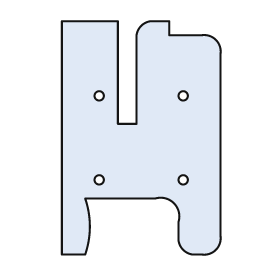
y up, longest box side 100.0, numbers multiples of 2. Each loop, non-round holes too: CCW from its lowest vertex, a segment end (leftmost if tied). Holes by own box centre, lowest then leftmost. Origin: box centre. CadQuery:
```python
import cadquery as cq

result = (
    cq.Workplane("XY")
    .moveTo(-34.0, -50.0)
    .lineTo(-24.0, -50.0)
    .threePointArc((-22.0, -38.0), (-24.0, -26.0))
    .lineTo(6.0, -26.0)
    .threePointArc((14.0, -28.0), (16.0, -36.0))
    .lineTo(16.0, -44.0)
    .threePointArc((18.0, -48.0), (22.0, -50.0))
    .lineTo(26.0, -50.0)
    .threePointArc((32.0, -48.0), (34.0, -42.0))
    .lineTo(34.0, 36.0)
    .threePointArc((32.0, 42.0), (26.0, 44.0))
    .lineTo(12.0, 44.0)
    .lineTo(12.0, 50.0)
    .lineTo(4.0, 50.0)
    .threePointArc((0.0, 48.0), (-2.0, 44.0))
    .lineTo(-2.0, 6.0)
    .lineTo(-10.0, 6.0)
    .lineTo(-10.0, 50.0)
    .lineTo(-34.0, 50.0)
    .close()
    .moveTo(-18.0, -18.0)
    .circle(2.0)
    .moveTo(18.0, -18.0)
    .circle(2.0)
    .moveTo(-18.0, 18.0)
    .circle(2.0)
    .moveTo(18.0, 18.0)
    .circle(2.0)
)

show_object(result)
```